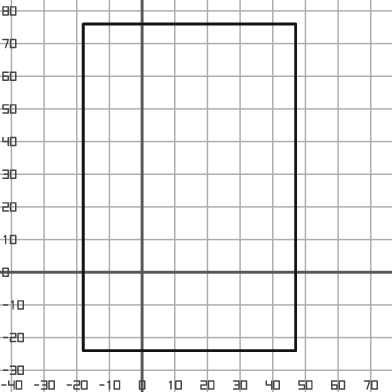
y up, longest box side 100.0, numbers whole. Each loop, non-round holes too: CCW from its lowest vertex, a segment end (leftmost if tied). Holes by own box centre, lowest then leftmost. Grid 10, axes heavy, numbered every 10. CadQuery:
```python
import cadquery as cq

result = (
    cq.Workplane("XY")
    .moveTo(-18.0, -24.0)
    .lineTo(47.0, -24.0)
    .lineTo(47.0, 76.0)
    .lineTo(-18.0, 76.0)
    .close()
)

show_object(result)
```